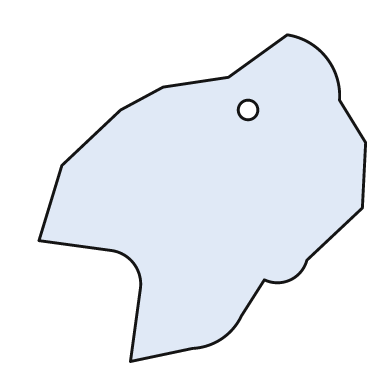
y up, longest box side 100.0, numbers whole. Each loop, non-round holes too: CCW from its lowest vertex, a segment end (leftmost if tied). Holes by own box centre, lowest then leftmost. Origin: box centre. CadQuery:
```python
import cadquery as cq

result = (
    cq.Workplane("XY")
    .moveTo(-22.0, -50.0)
    .lineTo(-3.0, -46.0)
    .threePointArc((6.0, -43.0), (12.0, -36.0))
    .lineTo(19.0, -25.0)
    .threePointArc((27.0, -25.0), (32.0, -19.0))
    .lineTo(49.0, -3.0)
    .lineTo(50.0, 17.0)
    .lineTo(42.0, 30.0)
    .threePointArc((38.0, 43.0), (26.0, 50.0))
    .lineTo(8.0, 37.0)
    .lineTo(-12.0, 34.0)
    .lineTo(-25.0, 27.0)
    .lineTo(-43.0, 10.0)
    .lineTo(-50.0, -13.0)
    .lineTo(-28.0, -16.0)
    .threePointArc((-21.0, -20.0), (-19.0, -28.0))
    .close()
    .moveTo(14.0, 27.0)
    .circle(3.0)
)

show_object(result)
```